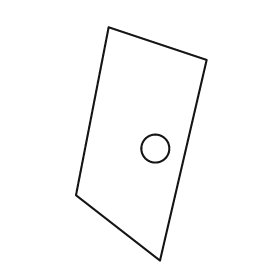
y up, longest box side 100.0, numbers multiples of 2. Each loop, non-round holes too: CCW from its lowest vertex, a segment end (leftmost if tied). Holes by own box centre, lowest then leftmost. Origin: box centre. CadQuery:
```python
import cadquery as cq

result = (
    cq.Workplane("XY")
    .moveTo(8.0, -50.0)
    .lineTo(28.0, 36.0)
    .lineTo(-14.0, 50.0)
    .lineTo(-28.0, -22.0)
    .close()
    .moveTo(6.0, -2.0)
    .circle(6.0)
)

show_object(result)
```